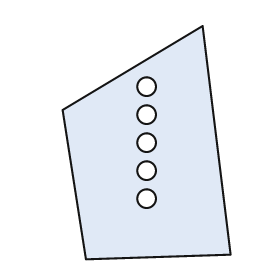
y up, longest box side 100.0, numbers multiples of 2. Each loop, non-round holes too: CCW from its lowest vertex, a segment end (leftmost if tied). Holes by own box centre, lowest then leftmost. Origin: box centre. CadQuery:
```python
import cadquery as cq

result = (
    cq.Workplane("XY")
    .moveTo(-26.0, -50.0)
    .lineTo(36.0, -48.0)
    .lineTo(24.0, 50.0)
    .lineTo(-36.0, 14.0)
    .close()
    .moveTo(0.0, -24.0)
    .circle(4.0)
    .moveTo(0.0, -12.0)
    .circle(4.0)
    .moveTo(0.0, 0.0)
    .circle(4.0)
    .moveTo(0.0, 12.0)
    .circle(4.0)
    .moveTo(0.0, 24.0)
    .circle(4.0)
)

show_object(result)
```